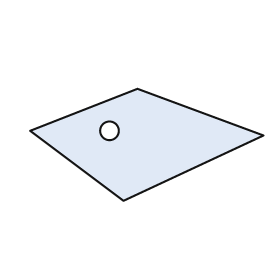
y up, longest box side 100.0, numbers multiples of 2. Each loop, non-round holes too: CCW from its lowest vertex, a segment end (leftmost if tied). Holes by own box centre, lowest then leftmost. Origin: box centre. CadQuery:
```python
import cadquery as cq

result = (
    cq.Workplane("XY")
    .moveTo(-10.0, -24.0)
    .lineTo(50.0, 4.0)
    .lineTo(-4.0, 24.0)
    .lineTo(-50.0, 6.0)
    .close()
    .moveTo(-16.0, 6.0)
    .circle(4.0)
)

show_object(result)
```